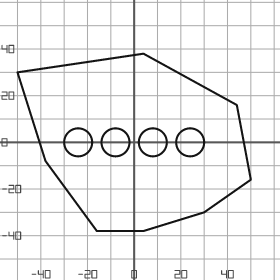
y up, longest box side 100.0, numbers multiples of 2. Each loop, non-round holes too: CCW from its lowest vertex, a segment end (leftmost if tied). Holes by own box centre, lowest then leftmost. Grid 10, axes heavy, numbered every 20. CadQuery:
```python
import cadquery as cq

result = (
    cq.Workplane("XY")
    .moveTo(-16.0, -38.0)
    .lineTo(4.0, -38.0)
    .lineTo(30.0, -30.0)
    .lineTo(50.0, -16.0)
    .lineTo(44.0, 16.0)
    .lineTo(4.0, 38.0)
    .lineTo(-50.0, 30.0)
    .lineTo(-38.0, -8.0)
    .close()
    .moveTo(-24.0, 0.0)
    .circle(6.0)
    .moveTo(-8.0, 0.0)
    .circle(6.0)
    .moveTo(8.0, 0.0)
    .circle(6.0)
    .moveTo(24.0, 0.0)
    .circle(6.0)
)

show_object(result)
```